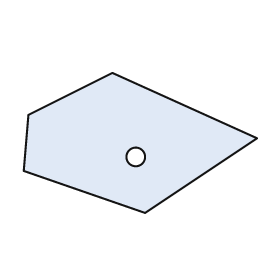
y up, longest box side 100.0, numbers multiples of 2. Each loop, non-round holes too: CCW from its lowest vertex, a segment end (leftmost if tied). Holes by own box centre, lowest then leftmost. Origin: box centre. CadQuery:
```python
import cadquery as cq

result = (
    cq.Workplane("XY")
    .moveTo(2.0, -30.0)
    .lineTo(50.0, 2.0)
    .lineTo(-12.0, 30.0)
    .lineTo(-48.0, 12.0)
    .lineTo(-50.0, -12.0)
    .close()
    .moveTo(-2.0, -6.0)
    .circle(4.0)
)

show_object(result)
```